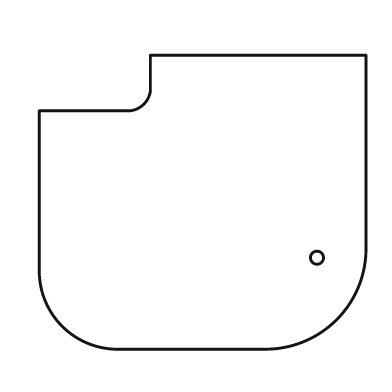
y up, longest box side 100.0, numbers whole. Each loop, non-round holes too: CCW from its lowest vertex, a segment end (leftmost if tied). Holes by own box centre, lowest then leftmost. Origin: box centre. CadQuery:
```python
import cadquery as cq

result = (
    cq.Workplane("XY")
    .moveTo(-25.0, -45.0)
    .lineTo(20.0, -45.0)
    .threePointArc((41.0, -36.0), (50.0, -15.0))
    .lineTo(50.0, 45.0)
    .lineTo(-16.0, 45.0)
    .lineTo(-16.0, 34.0)
    .threePointArc((-18.0, 30.0), (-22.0, 28.0))
    .lineTo(-50.0, 28.0)
    .lineTo(-50.0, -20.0)
    .threePointArc((-43.0, -38.0), (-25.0, -45.0))
    .close()
    .moveTo(35.0, -17.0)
    .circle(2.0)
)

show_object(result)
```